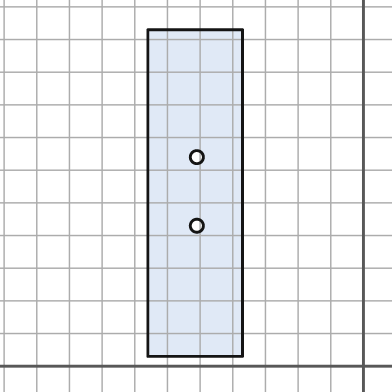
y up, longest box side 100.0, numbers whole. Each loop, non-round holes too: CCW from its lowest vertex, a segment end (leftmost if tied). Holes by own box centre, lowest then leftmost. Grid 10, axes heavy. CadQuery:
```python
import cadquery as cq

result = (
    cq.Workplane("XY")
    .moveTo(-66.0, 3.0)
    .lineTo(-37.0, 3.0)
    .lineTo(-37.0, 103.0)
    .lineTo(-66.0, 103.0)
    .close()
    .moveTo(-51.0, 43.0)
    .circle(2.0)
    .moveTo(-51.0, 64.0)
    .circle(2.0)
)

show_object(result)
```